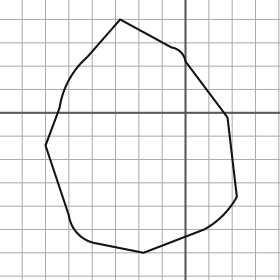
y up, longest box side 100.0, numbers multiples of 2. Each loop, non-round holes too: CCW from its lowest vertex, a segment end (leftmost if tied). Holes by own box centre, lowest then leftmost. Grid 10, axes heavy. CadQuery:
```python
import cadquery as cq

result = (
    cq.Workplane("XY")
    .moveTo(-18.0, -60.0)
    .lineTo(8.0, -50.0)
    .threePointArc((16.0, -44.0), (22.0, -36.0))
    .lineTo(18.0, -2.0)
    .lineTo(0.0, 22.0)
    .threePointArc((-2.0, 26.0), (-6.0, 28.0))
    .lineTo(-28.0, 40.0)
    .lineTo(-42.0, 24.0)
    .threePointArc((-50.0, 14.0), (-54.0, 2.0))
    .lineTo(-60.0, -14.0)
    .lineTo(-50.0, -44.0)
    .threePointArc((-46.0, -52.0), (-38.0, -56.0))
    .close()
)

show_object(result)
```